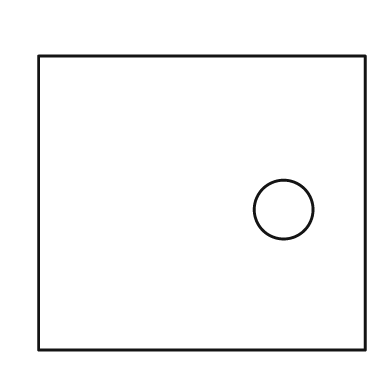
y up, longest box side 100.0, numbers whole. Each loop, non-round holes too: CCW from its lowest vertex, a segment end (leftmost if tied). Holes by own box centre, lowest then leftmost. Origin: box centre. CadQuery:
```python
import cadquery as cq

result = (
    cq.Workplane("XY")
    .moveTo(-50.0, -45.0)
    .lineTo(50.0, -45.0)
    .lineTo(50.0, 45.0)
    .lineTo(-50.0, 45.0)
    .close()
    .moveTo(25.0, -2.0)
    .circle(9.0)
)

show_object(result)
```